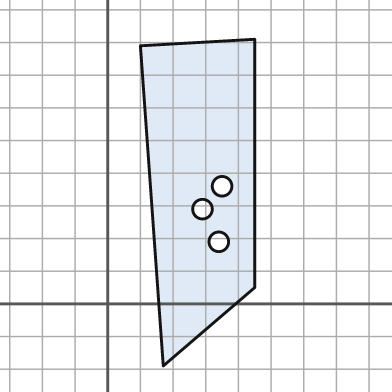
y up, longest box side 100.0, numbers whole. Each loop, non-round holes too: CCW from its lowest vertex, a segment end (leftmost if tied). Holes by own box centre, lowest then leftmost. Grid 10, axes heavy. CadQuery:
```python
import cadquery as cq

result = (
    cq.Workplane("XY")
    .moveTo(17.0, -19.0)
    .lineTo(45.0, 5.0)
    .lineTo(45.0, 81.0)
    .lineTo(10.0, 79.0)
    .close()
    .moveTo(34.0, 19.0)
    .circle(3.0)
    .moveTo(29.0, 29.0)
    .circle(3.0)
    .moveTo(35.0, 36.0)
    .circle(3.0)
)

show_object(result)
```